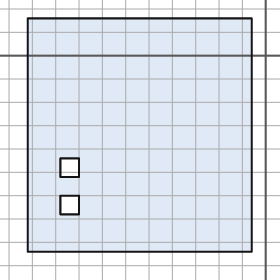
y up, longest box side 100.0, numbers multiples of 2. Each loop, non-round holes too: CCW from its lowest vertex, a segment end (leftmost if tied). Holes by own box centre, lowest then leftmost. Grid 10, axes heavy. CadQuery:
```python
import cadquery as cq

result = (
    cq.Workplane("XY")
    .moveTo(-102.0, -84.0)
    .lineTo(-6.0, -84.0)
    .lineTo(-6.0, 16.0)
    .lineTo(-102.0, 16.0)
    .close()
    .moveTo(-88.0, -68.0)
    .lineTo(-80.0, -68.0)
    .lineTo(-80.0, -60.0)
    .lineTo(-88.0, -60.0)
    .close()
    .moveTo(-88.0, -52.0)
    .lineTo(-80.0, -52.0)
    .lineTo(-80.0, -44.0)
    .lineTo(-88.0, -44.0)
    .close()
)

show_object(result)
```